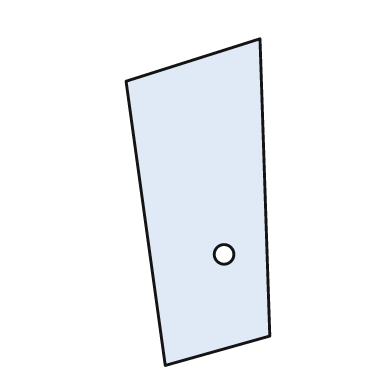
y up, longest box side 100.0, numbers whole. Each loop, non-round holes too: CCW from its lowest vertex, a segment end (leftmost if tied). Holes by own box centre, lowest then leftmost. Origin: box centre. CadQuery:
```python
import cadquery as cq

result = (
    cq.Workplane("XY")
    .moveTo(-10.0, -50.0)
    .lineTo(22.0, -41.0)
    .lineTo(19.0, 50.0)
    .lineTo(-22.0, 37.0)
    .close()
    .moveTo(8.0, -16.0)
    .circle(3.0)
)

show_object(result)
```